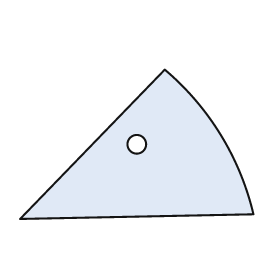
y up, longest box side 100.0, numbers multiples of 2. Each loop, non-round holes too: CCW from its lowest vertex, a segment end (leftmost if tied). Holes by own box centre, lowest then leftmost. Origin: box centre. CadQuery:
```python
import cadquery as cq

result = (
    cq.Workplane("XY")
    .moveTo(-50.0, -32.0)
    .lineTo(50.0, -30.0)
    .threePointArc((36.0, 4.0), (12.0, 32.0))
    .close()
    .moveTo(0.0, 0.0)
    .circle(4.0)
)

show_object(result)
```